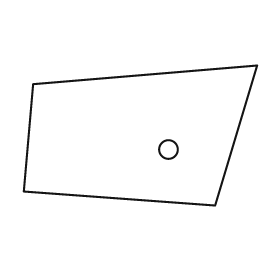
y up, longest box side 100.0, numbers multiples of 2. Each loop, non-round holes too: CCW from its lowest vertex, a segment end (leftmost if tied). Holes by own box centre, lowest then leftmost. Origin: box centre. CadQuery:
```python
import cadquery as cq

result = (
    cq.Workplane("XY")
    .moveTo(32.0, -30.0)
    .lineTo(50.0, 30.0)
    .lineTo(-46.0, 22.0)
    .lineTo(-50.0, -24.0)
    .close()
    .moveTo(12.0, -6.0)
    .circle(4.0)
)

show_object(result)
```